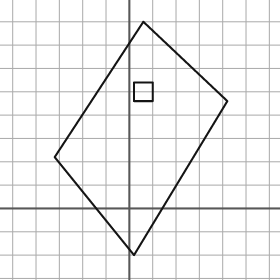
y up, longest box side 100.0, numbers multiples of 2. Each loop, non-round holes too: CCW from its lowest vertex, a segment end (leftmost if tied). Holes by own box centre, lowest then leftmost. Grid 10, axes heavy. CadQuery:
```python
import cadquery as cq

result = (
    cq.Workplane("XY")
    .moveTo(2.0, -20.0)
    .lineTo(42.0, 46.0)
    .lineTo(6.0, 80.0)
    .lineTo(-32.0, 22.0)
    .close()
    .moveTo(2.0, 46.0)
    .lineTo(10.0, 46.0)
    .lineTo(10.0, 54.0)
    .lineTo(2.0, 54.0)
    .close()
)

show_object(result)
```